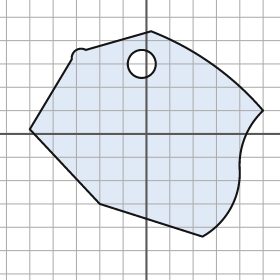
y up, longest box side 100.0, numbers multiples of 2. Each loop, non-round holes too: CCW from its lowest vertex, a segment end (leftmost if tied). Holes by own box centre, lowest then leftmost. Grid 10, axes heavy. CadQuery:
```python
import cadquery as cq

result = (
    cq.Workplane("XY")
    .moveTo(24.0, -44.0)
    .threePointArc((36.0, -32.0), (40.0, -16.0))
    .threePointArc((42.0, -2.0), (50.0, 10.0))
    .threePointArc((28.0, 30.0), (2.0, 44.0))
    .lineTo(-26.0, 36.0)
    .threePointArc((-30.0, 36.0), (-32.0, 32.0))
    .lineTo(-50.0, 2.0)
    .lineTo(-20.0, -30.0)
    .close()
    .moveTo(-2.0, 30.0)
    .circle(6.0)
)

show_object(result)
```